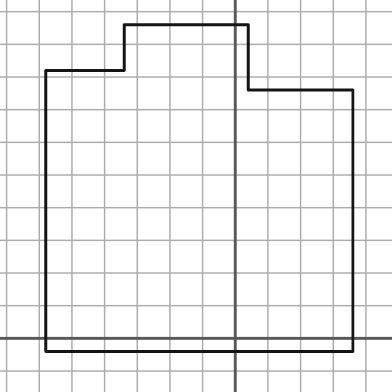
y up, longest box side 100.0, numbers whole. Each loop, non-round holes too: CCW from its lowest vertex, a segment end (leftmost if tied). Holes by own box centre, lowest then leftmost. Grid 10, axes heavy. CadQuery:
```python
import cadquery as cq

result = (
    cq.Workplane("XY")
    .moveTo(-58.0, -4.0)
    .lineTo(36.0, -4.0)
    .lineTo(36.0, 76.0)
    .lineTo(4.0, 76.0)
    .lineTo(4.0, 96.0)
    .lineTo(-34.0, 96.0)
    .lineTo(-34.0, 82.0)
    .lineTo(-58.0, 82.0)
    .close()
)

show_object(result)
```